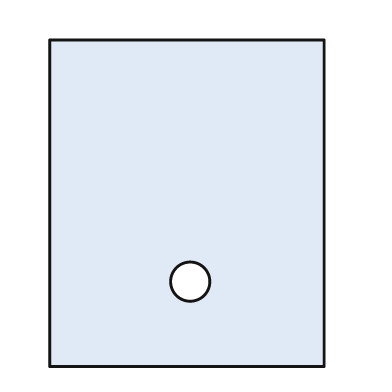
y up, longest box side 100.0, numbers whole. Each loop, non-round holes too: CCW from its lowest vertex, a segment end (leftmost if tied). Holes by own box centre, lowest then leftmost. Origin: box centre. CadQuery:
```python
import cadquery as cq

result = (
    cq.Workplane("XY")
    .moveTo(-42.0, -50.0)
    .lineTo(42.0, -50.0)
    .lineTo(42.0, 50.0)
    .lineTo(-42.0, 50.0)
    .close()
    .moveTo(1.0, -24.0)
    .circle(6.0)
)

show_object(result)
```